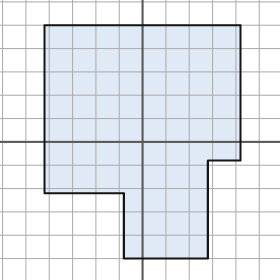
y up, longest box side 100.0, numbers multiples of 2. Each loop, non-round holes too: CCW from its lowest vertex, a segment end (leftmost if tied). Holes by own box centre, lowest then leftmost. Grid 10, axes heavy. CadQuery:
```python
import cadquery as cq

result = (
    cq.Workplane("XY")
    .moveTo(-8.0, -50.0)
    .lineTo(28.0, -50.0)
    .lineTo(28.0, -8.0)
    .lineTo(42.0, -8.0)
    .lineTo(42.0, 50.0)
    .lineTo(-42.0, 50.0)
    .lineTo(-42.0, -22.0)
    .lineTo(-8.0, -22.0)
    .close()
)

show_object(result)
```